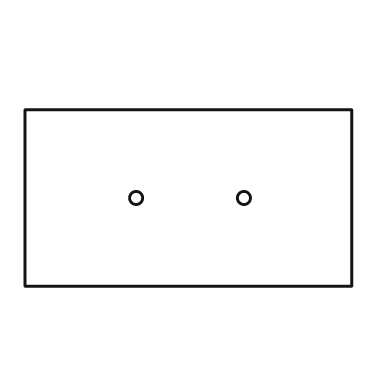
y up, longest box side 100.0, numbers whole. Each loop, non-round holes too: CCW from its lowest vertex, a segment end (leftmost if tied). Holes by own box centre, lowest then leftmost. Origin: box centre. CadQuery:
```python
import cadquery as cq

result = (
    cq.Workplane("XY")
    .moveTo(-50.0, -27.0)
    .lineTo(50.0, -27.0)
    .lineTo(50.0, 27.0)
    .lineTo(-50.0, 27.0)
    .close()
    .moveTo(-16.0, 0.0)
    .circle(2.0)
    .moveTo(17.0, 0.0)
    .circle(2.0)
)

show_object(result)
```